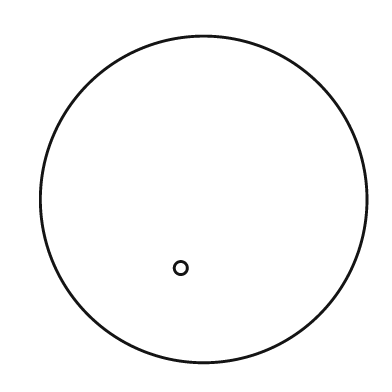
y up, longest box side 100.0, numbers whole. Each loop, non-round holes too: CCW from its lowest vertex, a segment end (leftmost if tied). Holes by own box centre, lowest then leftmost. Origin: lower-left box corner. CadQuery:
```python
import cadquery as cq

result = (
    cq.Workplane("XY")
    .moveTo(50.0, 50.0)
    .circle(50.0)
    .moveTo(43.0, 29.0)
    .circle(2.0)
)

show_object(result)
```